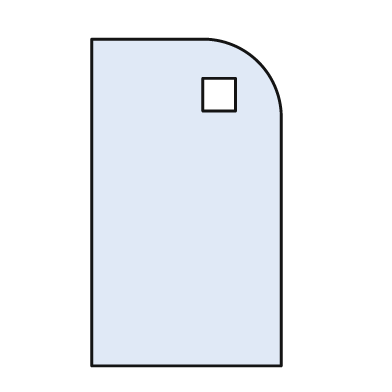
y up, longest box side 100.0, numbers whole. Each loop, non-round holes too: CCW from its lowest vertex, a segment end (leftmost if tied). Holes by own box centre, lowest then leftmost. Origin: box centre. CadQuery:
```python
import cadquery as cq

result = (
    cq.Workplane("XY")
    .moveTo(-29.0, -50.0)
    .lineTo(29.0, -50.0)
    .lineTo(29.0, 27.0)
    .threePointArc((22.0, 43.0), (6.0, 50.0))
    .lineTo(-29.0, 50.0)
    .close()
    .moveTo(5.0, 28.0)
    .lineTo(15.0, 28.0)
    .lineTo(15.0, 38.0)
    .lineTo(5.0, 38.0)
    .close()
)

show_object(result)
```